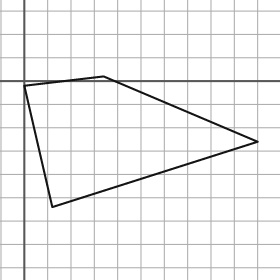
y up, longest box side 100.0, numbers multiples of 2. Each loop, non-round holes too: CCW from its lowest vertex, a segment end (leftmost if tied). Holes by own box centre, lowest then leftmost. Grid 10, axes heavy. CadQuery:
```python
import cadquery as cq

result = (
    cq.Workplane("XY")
    .moveTo(12.0, -54.0)
    .lineTo(100.0, -26.0)
    .lineTo(34.0, 2.0)
    .lineTo(0.0, -2.0)
    .close()
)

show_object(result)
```